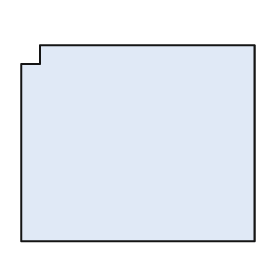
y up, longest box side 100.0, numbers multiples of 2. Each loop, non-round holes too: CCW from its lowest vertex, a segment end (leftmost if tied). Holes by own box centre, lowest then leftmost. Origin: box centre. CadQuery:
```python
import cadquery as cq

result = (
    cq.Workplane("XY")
    .moveTo(-50.0, -42.0)
    .lineTo(50.0, -42.0)
    .lineTo(50.0, 42.0)
    .lineTo(-42.0, 42.0)
    .lineTo(-42.0, 34.0)
    .lineTo(-50.0, 34.0)
    .close()
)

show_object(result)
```